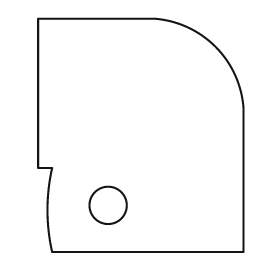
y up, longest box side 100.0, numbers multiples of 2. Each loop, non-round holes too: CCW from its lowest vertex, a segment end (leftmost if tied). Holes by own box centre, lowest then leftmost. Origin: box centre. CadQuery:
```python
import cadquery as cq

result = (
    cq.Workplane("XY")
    .moveTo(-38.0, -50.0)
    .lineTo(44.0, -50.0)
    .lineTo(44.0, 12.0)
    .threePointArc((32.0, 38.0), (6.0, 50.0))
    .lineTo(-44.0, 50.0)
    .lineTo(-44.0, -14.0)
    .lineTo(-38.0, -14.0)
    .threePointArc((-40.0, -32.0), (-38.0, -50.0))
    .close()
    .moveTo(-14.0, -30.0)
    .circle(8.0)
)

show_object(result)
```